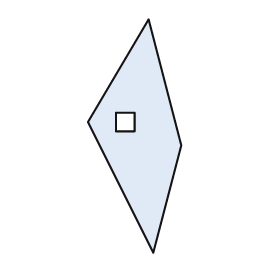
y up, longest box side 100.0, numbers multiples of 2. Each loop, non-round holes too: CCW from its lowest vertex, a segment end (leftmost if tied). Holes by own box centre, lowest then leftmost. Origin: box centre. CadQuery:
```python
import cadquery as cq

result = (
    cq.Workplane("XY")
    .moveTo(8.0, -50.0)
    .lineTo(20.0, -4.0)
    .lineTo(6.0, 50.0)
    .lineTo(-20.0, 6.0)
    .close()
    .moveTo(-8.0, 2.0)
    .lineTo(0.0, 2.0)
    .lineTo(0.0, 10.0)
    .lineTo(-8.0, 10.0)
    .close()
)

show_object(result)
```